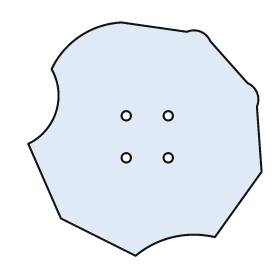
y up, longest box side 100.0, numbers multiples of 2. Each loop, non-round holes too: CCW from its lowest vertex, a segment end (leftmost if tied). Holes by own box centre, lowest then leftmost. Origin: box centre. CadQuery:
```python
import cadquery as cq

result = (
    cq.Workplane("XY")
    .moveTo(-4.0, -50.0)
    .threePointArc((12.0, -42.0), (30.0, -42.0))
    .lineTo(50.0, -14.0)
    .lineTo(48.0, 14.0)
    .threePointArc((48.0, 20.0), (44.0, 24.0))
    .lineTo(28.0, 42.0)
    .threePointArc((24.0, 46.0), (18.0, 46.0))
    .lineTo(-10.0, 50.0)
    .threePointArc((-28.0, 44.0), (-40.0, 30.0))
    .threePointArc((-38.0, 12.0), (-50.0, -2.0))
    .lineTo(-36.0, -34.0)
    .close()
    .moveTo(-8.0, -8.0)
    .circle(2.0)
    .moveTo(10.0, -8.0)
    .circle(2.0)
    .moveTo(-8.0, 10.0)
    .circle(2.0)
    .moveTo(10.0, 10.0)
    .circle(2.0)
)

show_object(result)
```